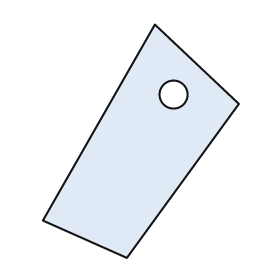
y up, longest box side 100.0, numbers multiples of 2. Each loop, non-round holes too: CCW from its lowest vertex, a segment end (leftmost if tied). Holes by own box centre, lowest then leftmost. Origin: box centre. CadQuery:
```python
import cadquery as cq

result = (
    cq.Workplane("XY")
    .moveTo(-6.0, -50.0)
    .lineTo(42.0, 16.0)
    .lineTo(6.0, 50.0)
    .lineTo(-42.0, -34.0)
    .close()
    .moveTo(14.0, 20.0)
    .circle(6.0)
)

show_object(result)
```